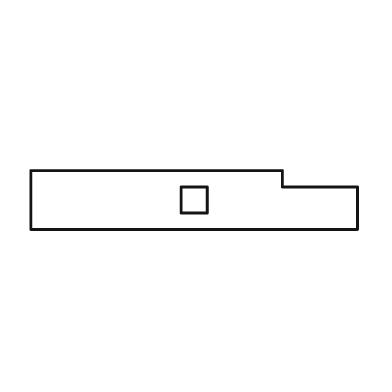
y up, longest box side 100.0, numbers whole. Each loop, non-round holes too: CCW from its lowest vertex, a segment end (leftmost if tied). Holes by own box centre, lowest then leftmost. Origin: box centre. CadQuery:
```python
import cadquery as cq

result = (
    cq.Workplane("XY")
    .moveTo(-50.0, -9.0)
    .lineTo(50.0, -9.0)
    .lineTo(50.0, 4.0)
    .lineTo(27.0, 4.0)
    .lineTo(27.0, 9.0)
    .lineTo(-50.0, 9.0)
    .close()
    .moveTo(-4.0, -4.0)
    .lineTo(4.0, -4.0)
    .lineTo(4.0, 4.0)
    .lineTo(-4.0, 4.0)
    .close()
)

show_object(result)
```